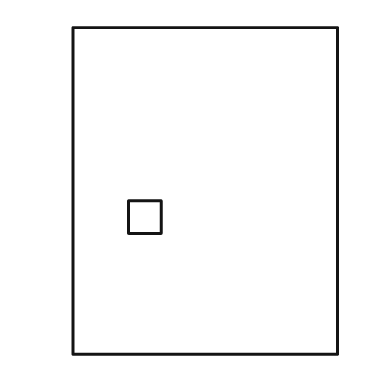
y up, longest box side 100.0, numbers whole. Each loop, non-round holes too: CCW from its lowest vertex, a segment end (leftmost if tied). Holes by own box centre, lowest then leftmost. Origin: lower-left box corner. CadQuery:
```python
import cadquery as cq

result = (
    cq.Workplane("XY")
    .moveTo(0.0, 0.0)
    .lineTo(81.0, 0.0)
    .lineTo(81.0, 100.0)
    .lineTo(0.0, 100.0)
    .close()
    .moveTo(17.0, 37.0)
    .lineTo(27.0, 37.0)
    .lineTo(27.0, 47.0)
    .lineTo(17.0, 47.0)
    .close()
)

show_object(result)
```